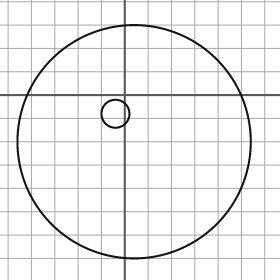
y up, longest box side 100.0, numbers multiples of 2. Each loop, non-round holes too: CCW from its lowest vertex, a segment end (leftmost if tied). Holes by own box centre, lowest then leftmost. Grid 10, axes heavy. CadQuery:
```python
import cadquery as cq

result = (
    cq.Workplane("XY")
    .moveTo(4.0, -20.0)
    .circle(50.0)
    .moveTo(-4.0, -8.0)
    .circle(6.0)
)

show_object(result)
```